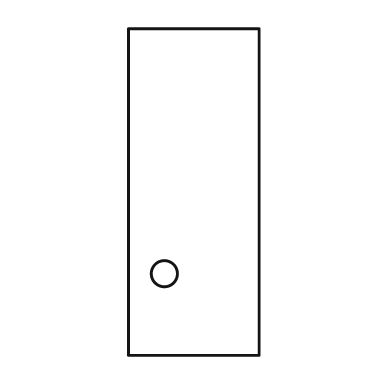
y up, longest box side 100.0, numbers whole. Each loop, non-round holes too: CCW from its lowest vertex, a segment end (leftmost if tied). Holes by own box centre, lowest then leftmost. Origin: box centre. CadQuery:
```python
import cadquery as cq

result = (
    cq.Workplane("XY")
    .moveTo(-20.0, -50.0)
    .lineTo(20.0, -50.0)
    .lineTo(20.0, 50.0)
    .lineTo(-20.0, 50.0)
    .close()
    .moveTo(-9.0, -25.0)
    .circle(4.0)
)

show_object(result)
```